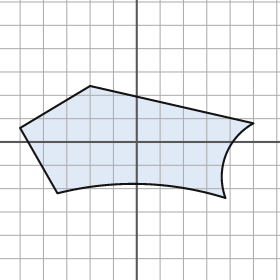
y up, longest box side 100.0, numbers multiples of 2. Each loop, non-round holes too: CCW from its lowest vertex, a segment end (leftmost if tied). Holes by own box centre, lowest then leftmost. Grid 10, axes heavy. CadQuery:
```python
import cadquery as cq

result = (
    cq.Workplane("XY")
    .moveTo(38.0, -24.0)
    .threePointArc((38.0, -6.0), (50.0, 8.0))
    .lineTo(-20.0, 24.0)
    .lineTo(-50.0, 6.0)
    .lineTo(-34.0, -22.0)
    .threePointArc((2.0, -18.0), (38.0, -24.0))
    .close()
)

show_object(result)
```